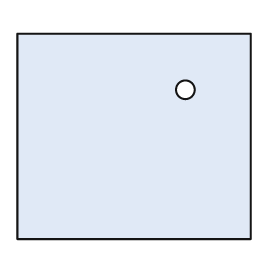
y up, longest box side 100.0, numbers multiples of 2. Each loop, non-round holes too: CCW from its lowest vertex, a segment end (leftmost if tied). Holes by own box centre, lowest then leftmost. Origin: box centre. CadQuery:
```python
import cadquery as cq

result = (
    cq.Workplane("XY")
    .moveTo(-50.0, -44.0)
    .lineTo(50.0, -44.0)
    .lineTo(50.0, 44.0)
    .lineTo(-50.0, 44.0)
    .close()
    .moveTo(22.0, 20.0)
    .circle(4.0)
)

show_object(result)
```